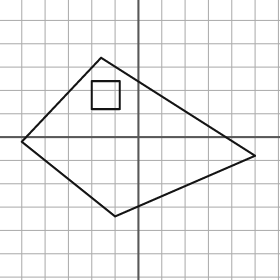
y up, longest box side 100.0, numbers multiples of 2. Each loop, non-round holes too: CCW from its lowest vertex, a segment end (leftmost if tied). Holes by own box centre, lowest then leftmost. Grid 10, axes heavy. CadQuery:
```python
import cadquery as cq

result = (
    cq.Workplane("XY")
    .moveTo(-10.0, -34.0)
    .lineTo(50.0, -8.0)
    .lineTo(-16.0, 34.0)
    .lineTo(-50.0, -2.0)
    .close()
    .moveTo(-20.0, 12.0)
    .lineTo(-8.0, 12.0)
    .lineTo(-8.0, 24.0)
    .lineTo(-20.0, 24.0)
    .close()
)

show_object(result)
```